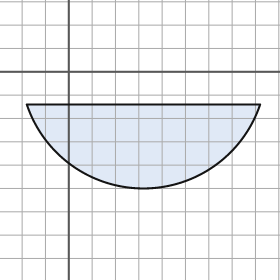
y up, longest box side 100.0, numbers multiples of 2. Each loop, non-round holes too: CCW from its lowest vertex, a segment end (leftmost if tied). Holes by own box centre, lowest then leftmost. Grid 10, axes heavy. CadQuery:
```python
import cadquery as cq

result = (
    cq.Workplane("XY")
    .moveTo(-18.0, -14.0)
    .threePointArc((32.0, -50.0), (82.0, -14.0))
    .close()
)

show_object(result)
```